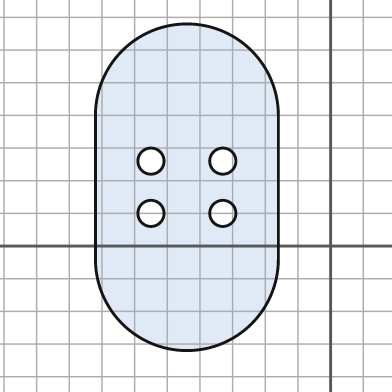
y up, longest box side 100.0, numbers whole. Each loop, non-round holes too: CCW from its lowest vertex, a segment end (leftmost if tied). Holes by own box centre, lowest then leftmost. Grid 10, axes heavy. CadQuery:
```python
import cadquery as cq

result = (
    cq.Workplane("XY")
    .moveTo(-72.0, -4.0)
    .threePointArc((-44.0, -32.0), (-16.0, -4.0))
    .lineTo(-16.0, 40.0)
    .threePointArc((-44.0, 68.0), (-72.0, 40.0))
    .close()
    .moveTo(-55.0, 10.0)
    .circle(4.0)
    .moveTo(-33.0, 10.0)
    .circle(4.0)
    .moveTo(-55.0, 26.0)
    .circle(4.0)
    .moveTo(-33.0, 26.0)
    .circle(4.0)
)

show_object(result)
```